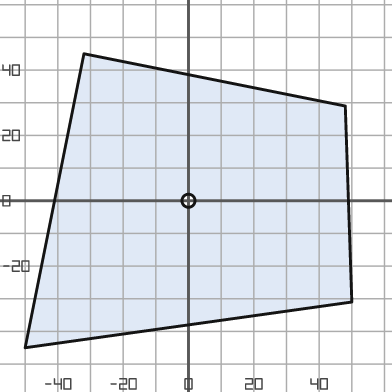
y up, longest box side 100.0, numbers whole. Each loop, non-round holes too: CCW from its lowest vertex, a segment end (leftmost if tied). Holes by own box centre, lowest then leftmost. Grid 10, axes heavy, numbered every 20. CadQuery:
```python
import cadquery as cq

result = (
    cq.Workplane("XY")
    .moveTo(-50.0, -45.0)
    .lineTo(50.0, -31.0)
    .lineTo(48.0, 29.0)
    .lineTo(-32.0, 45.0)
    .close()
    .moveTo(0.0, 0.0)
    .circle(2.0)
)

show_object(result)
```